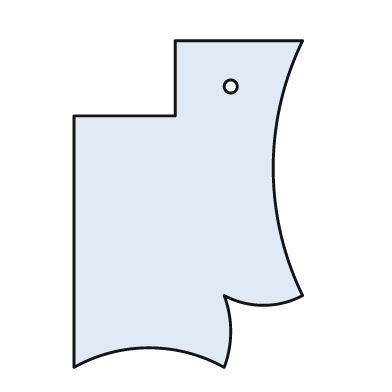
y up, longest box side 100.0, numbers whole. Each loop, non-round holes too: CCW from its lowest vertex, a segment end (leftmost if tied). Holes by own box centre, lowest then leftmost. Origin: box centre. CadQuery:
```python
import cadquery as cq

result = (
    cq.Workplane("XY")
    .moveTo(-35.0, -50.0)
    .threePointArc((-12.0, -44.0), (11.0, -50.0))
    .threePointArc((13.0, -39.0), (11.0, -28.0))
    .threePointArc((23.0, -31.0), (35.0, -28.0))
    .threePointArc((26.0, 11.0), (35.0, 50.0))
    .lineTo(-4.0, 50.0)
    .lineTo(-4.0, 27.0)
    .lineTo(-35.0, 27.0)
    .close()
    .moveTo(13.0, 36.0)
    .circle(2.0)
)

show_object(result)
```